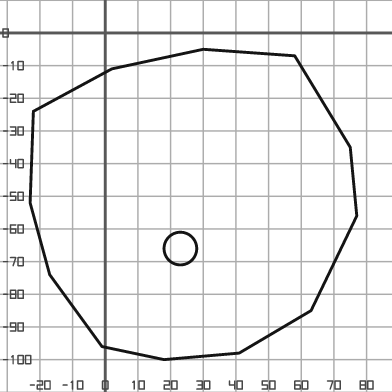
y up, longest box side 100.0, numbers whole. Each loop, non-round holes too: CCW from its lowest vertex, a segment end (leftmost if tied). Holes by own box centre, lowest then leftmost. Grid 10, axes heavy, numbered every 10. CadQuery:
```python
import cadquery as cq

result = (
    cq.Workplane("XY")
    .moveTo(18.0, -100.0)
    .lineTo(41.0, -98.0)
    .lineTo(63.0, -85.0)
    .lineTo(77.0, -56.0)
    .lineTo(75.0, -35.0)
    .lineTo(58.0, -7.0)
    .lineTo(30.0, -5.0)
    .lineTo(2.0, -11.0)
    .lineTo(-22.0, -24.0)
    .lineTo(-23.0, -52.0)
    .lineTo(-17.0, -74.0)
    .lineTo(-1.0, -96.0)
    .close()
    .moveTo(23.0, -66.0)
    .circle(5.0)
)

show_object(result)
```